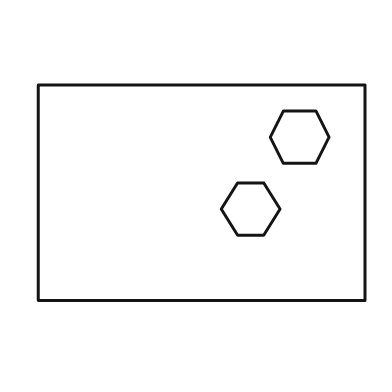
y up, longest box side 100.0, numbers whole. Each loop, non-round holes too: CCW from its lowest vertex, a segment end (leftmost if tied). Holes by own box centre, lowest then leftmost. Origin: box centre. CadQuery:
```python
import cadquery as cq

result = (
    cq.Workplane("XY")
    .moveTo(-50.0, -33.0)
    .lineTo(50.0, -33.0)
    .lineTo(50.0, 33.0)
    .lineTo(-50.0, 33.0)
    .close()
    .moveTo(11.0, -13.0)
    .lineTo(19.0, -13.0)
    .lineTo(24.0, -5.0)
    .lineTo(19.0, 3.0)
    .lineTo(11.0, 3.0)
    .lineTo(6.0, -5.0)
    .close()
    .moveTo(25.0, 9.0)
    .lineTo(35.0, 9.0)
    .lineTo(39.0, 17.0)
    .lineTo(35.0, 25.0)
    .lineTo(25.0, 25.0)
    .lineTo(21.0, 17.0)
    .close()
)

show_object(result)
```